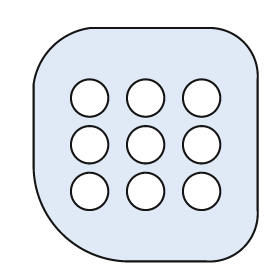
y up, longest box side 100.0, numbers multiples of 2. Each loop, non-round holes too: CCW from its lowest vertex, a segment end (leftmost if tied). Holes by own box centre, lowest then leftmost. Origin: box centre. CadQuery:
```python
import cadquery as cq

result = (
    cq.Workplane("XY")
    .moveTo(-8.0, -50.0)
    .lineTo(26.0, -50.0)
    .threePointArc((42.0, -44.0), (48.0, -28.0))
    .lineTo(48.0, 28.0)
    .threePointArc((42.0, 44.0), (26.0, 50.0))
    .lineTo(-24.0, 50.0)
    .threePointArc((-40.0, 42.0), (-48.0, 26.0))
    .lineTo(-48.0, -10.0)
    .threePointArc((-36.0, -38.0), (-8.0, -50.0))
    .close()
    .moveTo(-24.0, -20.0)
    .circle(8.0)
    .moveTo(0.0, -20.0)
    .circle(8.0)
    .moveTo(24.0, -20.0)
    .circle(8.0)
    .moveTo(-24.0, 0.0)
    .circle(8.0)
    .moveTo(0.0, 0.0)
    .circle(8.0)
    .moveTo(24.0, 0.0)
    .circle(8.0)
    .moveTo(-24.0, 20.0)
    .circle(8.0)
    .moveTo(0.0, 20.0)
    .circle(8.0)
    .moveTo(24.0, 20.0)
    .circle(8.0)
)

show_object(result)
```